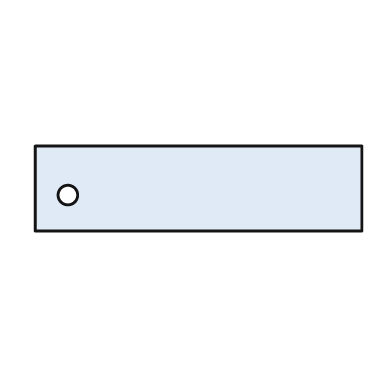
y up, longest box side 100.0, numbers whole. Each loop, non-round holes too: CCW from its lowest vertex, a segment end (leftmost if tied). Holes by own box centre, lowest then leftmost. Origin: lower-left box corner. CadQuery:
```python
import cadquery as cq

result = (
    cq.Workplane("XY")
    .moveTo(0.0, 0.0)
    .lineTo(100.0, 0.0)
    .lineTo(100.0, 26.0)
    .lineTo(0.0, 26.0)
    .close()
    .moveTo(10.0, 11.0)
    .circle(3.0)
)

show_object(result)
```